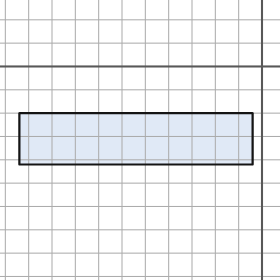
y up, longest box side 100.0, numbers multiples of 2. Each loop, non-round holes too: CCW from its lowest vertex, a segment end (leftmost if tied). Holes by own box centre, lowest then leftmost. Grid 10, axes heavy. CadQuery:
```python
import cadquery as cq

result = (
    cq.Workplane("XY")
    .moveTo(-104.0, -42.0)
    .lineTo(-4.0, -42.0)
    .lineTo(-4.0, -20.0)
    .lineTo(-104.0, -20.0)
    .close()
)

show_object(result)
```